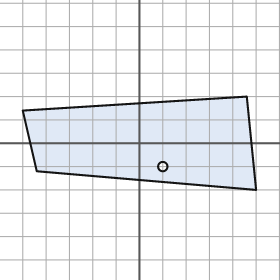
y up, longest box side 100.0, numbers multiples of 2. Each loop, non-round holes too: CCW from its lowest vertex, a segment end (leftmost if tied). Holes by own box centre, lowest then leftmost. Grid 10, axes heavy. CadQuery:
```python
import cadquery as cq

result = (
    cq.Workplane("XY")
    .moveTo(50.0, -20.0)
    .lineTo(46.0, 20.0)
    .lineTo(-50.0, 14.0)
    .lineTo(-44.0, -12.0)
    .close()
    .moveTo(10.0, -10.0)
    .circle(2.0)
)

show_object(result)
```